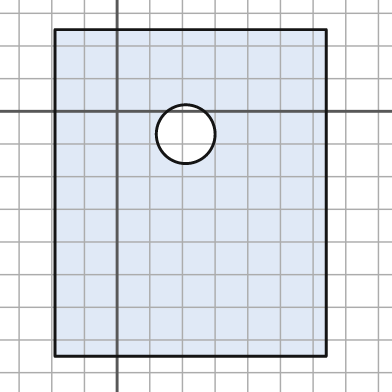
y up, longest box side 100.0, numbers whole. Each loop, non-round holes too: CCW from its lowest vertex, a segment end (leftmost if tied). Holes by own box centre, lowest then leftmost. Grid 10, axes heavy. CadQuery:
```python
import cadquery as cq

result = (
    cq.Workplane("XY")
    .moveTo(-19.0, -75.0)
    .lineTo(64.0, -75.0)
    .lineTo(64.0, 25.0)
    .lineTo(-19.0, 25.0)
    .close()
    .moveTo(21.0, -7.0)
    .circle(9.0)
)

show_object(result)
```